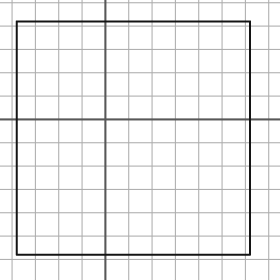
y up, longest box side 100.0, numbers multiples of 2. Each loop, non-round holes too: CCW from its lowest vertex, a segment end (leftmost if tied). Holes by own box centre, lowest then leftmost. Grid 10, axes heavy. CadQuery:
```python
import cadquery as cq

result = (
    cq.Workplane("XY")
    .moveTo(-38.0, -58.0)
    .lineTo(62.0, -58.0)
    .lineTo(62.0, 42.0)
    .lineTo(-38.0, 42.0)
    .close()
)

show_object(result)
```